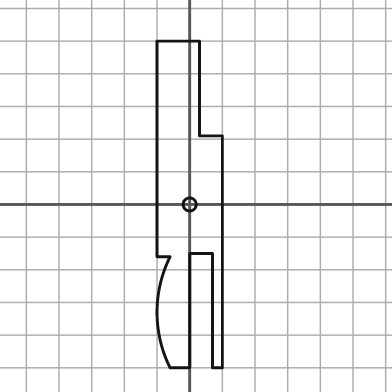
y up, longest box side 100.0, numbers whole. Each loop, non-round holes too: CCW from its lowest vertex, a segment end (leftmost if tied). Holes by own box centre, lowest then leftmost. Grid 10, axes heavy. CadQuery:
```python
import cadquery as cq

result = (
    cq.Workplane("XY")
    .moveTo(-6.0, -50.0)
    .lineTo(0.0, -50.0)
    .lineTo(0.0, -15.0)
    .lineTo(7.0, -15.0)
    .lineTo(7.0, -50.0)
    .lineTo(10.0, -50.0)
    .lineTo(10.0, 21.0)
    .lineTo(3.0, 21.0)
    .lineTo(3.0, 50.0)
    .lineTo(-10.0, 50.0)
    .lineTo(-10.0, -16.0)
    .lineTo(-6.0, -16.0)
    .threePointArc((-10.0, -33.0), (-6.0, -50.0))
    .close()
    .moveTo(0.0, 0.0)
    .circle(2.0)
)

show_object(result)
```